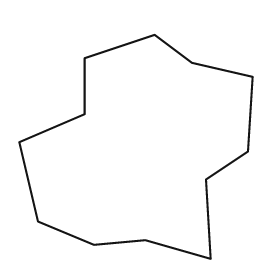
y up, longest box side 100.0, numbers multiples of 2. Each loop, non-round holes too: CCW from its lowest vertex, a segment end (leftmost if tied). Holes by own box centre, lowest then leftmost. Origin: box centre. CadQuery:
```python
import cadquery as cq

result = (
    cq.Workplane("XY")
    .moveTo(32.0, -48.0)
    .lineTo(30.0, -14.0)
    .lineTo(48.0, -2.0)
    .lineTo(50.0, 30.0)
    .lineTo(24.0, 36.0)
    .lineTo(8.0, 48.0)
    .lineTo(-22.0, 38.0)
    .lineTo(-22.0, 14.0)
    .lineTo(-50.0, 2.0)
    .lineTo(-42.0, -32.0)
    .lineTo(-18.0, -42.0)
    .lineTo(4.0, -40.0)
    .close()
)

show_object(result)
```